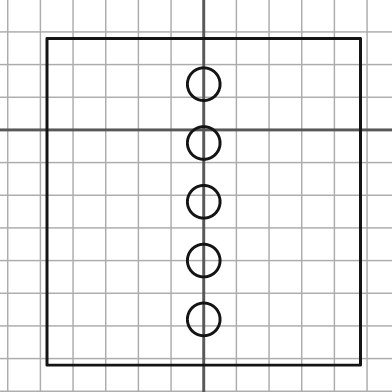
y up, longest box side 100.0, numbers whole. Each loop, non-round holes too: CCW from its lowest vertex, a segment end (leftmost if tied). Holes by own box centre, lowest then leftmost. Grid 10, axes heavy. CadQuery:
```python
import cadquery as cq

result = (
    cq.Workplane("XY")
    .moveTo(-48.0, -72.0)
    .lineTo(48.0, -72.0)
    .lineTo(48.0, 28.0)
    .lineTo(-48.0, 28.0)
    .close()
    .moveTo(0.0, -58.0)
    .circle(5.0)
    .moveTo(0.0, -40.0)
    .circle(5.0)
    .moveTo(0.0, -22.0)
    .circle(5.0)
    .moveTo(0.0, -4.0)
    .circle(5.0)
    .moveTo(0.0, 14.0)
    .circle(5.0)
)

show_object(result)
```